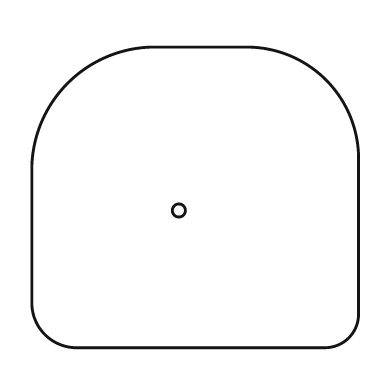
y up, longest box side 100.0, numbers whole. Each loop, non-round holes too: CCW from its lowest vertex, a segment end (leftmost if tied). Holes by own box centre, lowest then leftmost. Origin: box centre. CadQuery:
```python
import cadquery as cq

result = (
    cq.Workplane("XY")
    .moveTo(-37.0, -46.0)
    .lineTo(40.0, -46.0)
    .threePointArc((47.0, -43.0), (50.0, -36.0))
    .lineTo(50.0, 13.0)
    .threePointArc((40.0, 36.0), (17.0, 46.0))
    .lineTo(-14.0, 46.0)
    .threePointArc((-39.0, 35.0), (-50.0, 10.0))
    .lineTo(-50.0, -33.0)
    .threePointArc((-46.0, -42.0), (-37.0, -46.0))
    .close()
    .moveTo(-5.0, -4.0)
    .circle(2.0)
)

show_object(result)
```